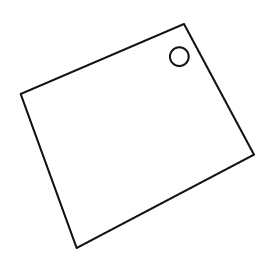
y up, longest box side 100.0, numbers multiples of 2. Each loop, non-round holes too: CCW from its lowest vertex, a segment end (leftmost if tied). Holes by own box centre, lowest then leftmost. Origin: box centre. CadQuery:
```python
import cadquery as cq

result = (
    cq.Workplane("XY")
    .moveTo(-26.0, -48.0)
    .lineTo(50.0, -8.0)
    .lineTo(20.0, 48.0)
    .lineTo(-50.0, 18.0)
    .close()
    .moveTo(18.0, 34.0)
    .circle(4.0)
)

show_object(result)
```